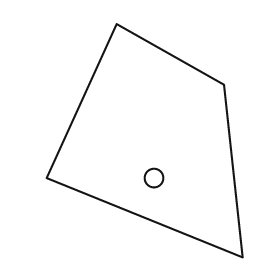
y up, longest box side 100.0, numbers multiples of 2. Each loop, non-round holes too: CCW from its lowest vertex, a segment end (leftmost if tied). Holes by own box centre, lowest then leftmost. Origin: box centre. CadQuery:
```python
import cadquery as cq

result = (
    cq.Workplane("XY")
    .moveTo(42.0, -50.0)
    .lineTo(34.0, 24.0)
    .lineTo(-12.0, 50.0)
    .lineTo(-42.0, -16.0)
    .close()
    .moveTo(4.0, -16.0)
    .circle(4.0)
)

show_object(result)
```